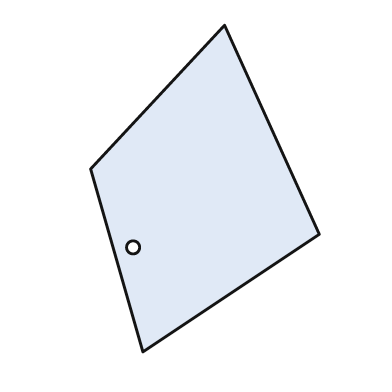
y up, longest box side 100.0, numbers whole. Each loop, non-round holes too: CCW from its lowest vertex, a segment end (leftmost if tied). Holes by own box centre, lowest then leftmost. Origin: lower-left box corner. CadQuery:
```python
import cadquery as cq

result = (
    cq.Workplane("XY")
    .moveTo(16.0, 0.0)
    .lineTo(70.0, 36.0)
    .lineTo(41.0, 100.0)
    .lineTo(0.0, 56.0)
    .close()
    .moveTo(13.0, 32.0)
    .circle(2.0)
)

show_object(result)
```